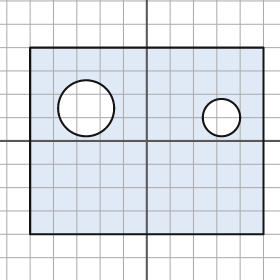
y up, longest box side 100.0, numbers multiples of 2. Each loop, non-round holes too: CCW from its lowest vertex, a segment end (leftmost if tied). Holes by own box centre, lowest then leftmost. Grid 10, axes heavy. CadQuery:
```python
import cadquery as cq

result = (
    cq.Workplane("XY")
    .moveTo(-50.0, -40.0)
    .lineTo(50.0, -40.0)
    .lineTo(50.0, 40.0)
    .lineTo(-50.0, 40.0)
    .close()
    .moveTo(32.0, 10.0)
    .circle(8.0)
    .moveTo(-26.0, 14.0)
    .circle(12.0)
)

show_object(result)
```